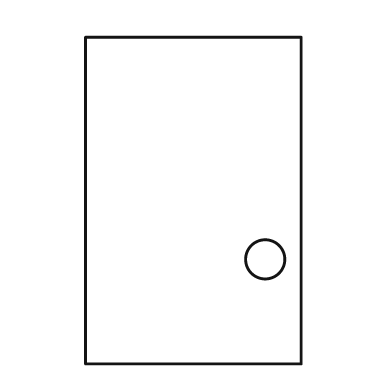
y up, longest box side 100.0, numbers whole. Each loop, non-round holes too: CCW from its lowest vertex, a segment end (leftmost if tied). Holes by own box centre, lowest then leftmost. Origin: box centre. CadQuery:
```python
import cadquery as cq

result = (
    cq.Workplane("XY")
    .moveTo(-33.0, -50.0)
    .lineTo(33.0, -50.0)
    .lineTo(33.0, 50.0)
    .lineTo(-33.0, 50.0)
    .close()
    .moveTo(22.0, -18.0)
    .circle(6.0)
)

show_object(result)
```